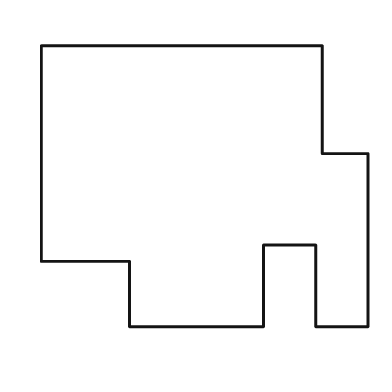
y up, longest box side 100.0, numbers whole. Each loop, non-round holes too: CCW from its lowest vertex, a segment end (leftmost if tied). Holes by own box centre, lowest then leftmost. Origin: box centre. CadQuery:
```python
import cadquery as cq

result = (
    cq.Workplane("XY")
    .moveTo(-23.0, -43.0)
    .lineTo(18.0, -43.0)
    .lineTo(18.0, -18.0)
    .lineTo(34.0, -18.0)
    .lineTo(34.0, -43.0)
    .lineTo(50.0, -43.0)
    .lineTo(50.0, 10.0)
    .lineTo(36.0, 10.0)
    .lineTo(36.0, 43.0)
    .lineTo(-50.0, 43.0)
    .lineTo(-50.0, -23.0)
    .lineTo(-23.0, -23.0)
    .close()
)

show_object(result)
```